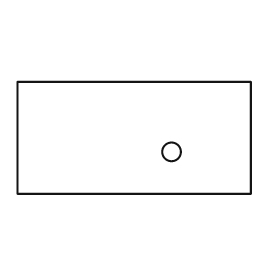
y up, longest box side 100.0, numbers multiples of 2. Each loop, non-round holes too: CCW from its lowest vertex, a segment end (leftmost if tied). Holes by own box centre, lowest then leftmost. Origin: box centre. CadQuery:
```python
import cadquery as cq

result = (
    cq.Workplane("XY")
    .moveTo(-50.0, -24.0)
    .lineTo(50.0, -24.0)
    .lineTo(50.0, 24.0)
    .lineTo(-50.0, 24.0)
    .close()
    .moveTo(16.0, -6.0)
    .circle(4.0)
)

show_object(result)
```